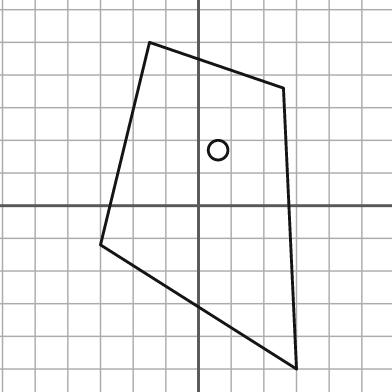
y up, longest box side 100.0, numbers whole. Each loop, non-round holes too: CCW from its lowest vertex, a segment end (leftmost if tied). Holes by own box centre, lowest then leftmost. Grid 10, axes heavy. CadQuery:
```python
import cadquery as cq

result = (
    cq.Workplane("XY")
    .moveTo(30.0, -50.0)
    .lineTo(26.0, 36.0)
    .lineTo(-15.0, 50.0)
    .lineTo(-30.0, -12.0)
    .close()
    .moveTo(6.0, 17.0)
    .circle(3.0)
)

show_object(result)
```